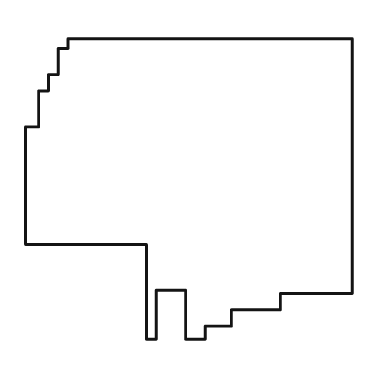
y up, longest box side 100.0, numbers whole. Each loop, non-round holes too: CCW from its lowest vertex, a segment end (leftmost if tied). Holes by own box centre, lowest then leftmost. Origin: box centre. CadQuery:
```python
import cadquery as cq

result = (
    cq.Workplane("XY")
    .moveTo(-13.0, -46.0)
    .lineTo(-10.0, -46.0)
    .lineTo(-10.0, -31.0)
    .lineTo(-1.0, -31.0)
    .lineTo(-1.0, -46.0)
    .lineTo(5.0, -46.0)
    .lineTo(5.0, -42.0)
    .lineTo(13.0, -42.0)
    .lineTo(13.0, -37.0)
    .lineTo(28.0, -37.0)
    .lineTo(28.0, -32.0)
    .lineTo(50.0, -32.0)
    .lineTo(50.0, 46.0)
    .lineTo(-37.0, 46.0)
    .lineTo(-37.0, 43.0)
    .lineTo(-40.0, 43.0)
    .lineTo(-40.0, 35.0)
    .lineTo(-43.0, 35.0)
    .lineTo(-43.0, 30.0)
    .lineTo(-46.0, 30.0)
    .lineTo(-46.0, 19.0)
    .lineTo(-50.0, 19.0)
    .lineTo(-50.0, -17.0)
    .lineTo(-13.0, -17.0)
    .close()
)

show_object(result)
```